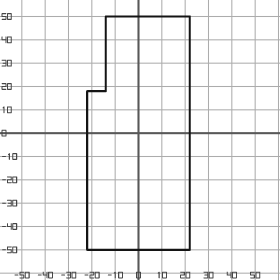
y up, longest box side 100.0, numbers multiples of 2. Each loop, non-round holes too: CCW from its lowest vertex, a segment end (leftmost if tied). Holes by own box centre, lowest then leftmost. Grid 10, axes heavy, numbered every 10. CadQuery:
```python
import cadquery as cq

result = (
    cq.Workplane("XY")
    .moveTo(-22.0, -50.0)
    .lineTo(22.0, -50.0)
    .lineTo(22.0, 50.0)
    .lineTo(-14.0, 50.0)
    .lineTo(-14.0, 18.0)
    .lineTo(-22.0, 18.0)
    .close()
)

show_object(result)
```